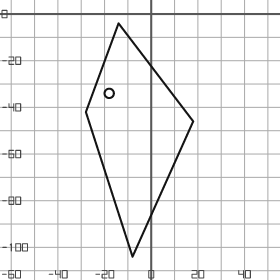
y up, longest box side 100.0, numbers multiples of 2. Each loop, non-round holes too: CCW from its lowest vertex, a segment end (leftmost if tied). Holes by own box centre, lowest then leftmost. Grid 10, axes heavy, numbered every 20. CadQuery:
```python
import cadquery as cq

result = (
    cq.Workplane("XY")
    .moveTo(-8.0, -104.0)
    .lineTo(18.0, -46.0)
    .lineTo(-14.0, -4.0)
    .lineTo(-28.0, -42.0)
    .close()
    .moveTo(-18.0, -34.0)
    .circle(2.0)
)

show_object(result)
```